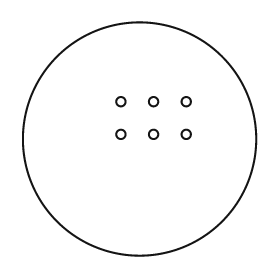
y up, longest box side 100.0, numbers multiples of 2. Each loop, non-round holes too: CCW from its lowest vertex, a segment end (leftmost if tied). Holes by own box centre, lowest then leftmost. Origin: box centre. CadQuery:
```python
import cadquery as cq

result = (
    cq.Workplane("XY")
    .moveTo(0.0, 0.0)
    .circle(50.0)
    .moveTo(-8.0, 2.0)
    .circle(2.0)
    .moveTo(6.0, 2.0)
    .circle(2.0)
    .moveTo(20.0, 2.0)
    .circle(2.0)
    .moveTo(-8.0, 16.0)
    .circle(2.0)
    .moveTo(6.0, 16.0)
    .circle(2.0)
    .moveTo(20.0, 16.0)
    .circle(2.0)
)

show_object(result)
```